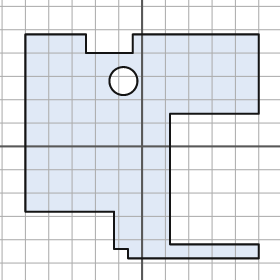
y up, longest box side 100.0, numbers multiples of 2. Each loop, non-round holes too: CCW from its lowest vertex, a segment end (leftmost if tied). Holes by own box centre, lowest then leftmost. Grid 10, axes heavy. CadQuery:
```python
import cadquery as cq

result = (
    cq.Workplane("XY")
    .moveTo(-6.0, -48.0)
    .lineTo(50.0, -48.0)
    .lineTo(50.0, -42.0)
    .lineTo(12.0, -42.0)
    .lineTo(12.0, 14.0)
    .lineTo(50.0, 14.0)
    .lineTo(50.0, 48.0)
    .lineTo(-4.0, 48.0)
    .lineTo(-4.0, 40.0)
    .lineTo(-24.0, 40.0)
    .lineTo(-24.0, 48.0)
    .lineTo(-50.0, 48.0)
    .lineTo(-50.0, -28.0)
    .lineTo(-12.0, -28.0)
    .lineTo(-12.0, -44.0)
    .lineTo(-6.0, -44.0)
    .close()
    .moveTo(-8.0, 28.0)
    .circle(6.0)
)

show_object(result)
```